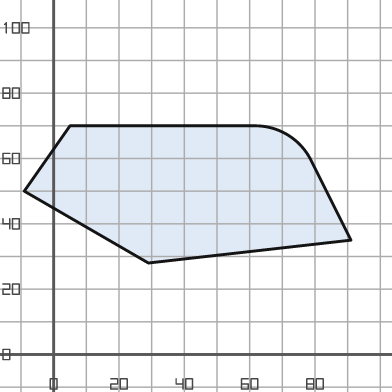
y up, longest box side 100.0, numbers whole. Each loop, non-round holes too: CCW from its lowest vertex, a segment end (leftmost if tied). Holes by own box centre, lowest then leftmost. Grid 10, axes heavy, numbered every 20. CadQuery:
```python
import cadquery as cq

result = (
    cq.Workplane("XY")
    .moveTo(29.0, 28.0)
    .lineTo(91.0, 35.0)
    .lineTo(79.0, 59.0)
    .threePointArc((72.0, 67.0), (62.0, 70.0))
    .lineTo(5.0, 70.0)
    .lineTo(-9.0, 50.0)
    .close()
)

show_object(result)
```